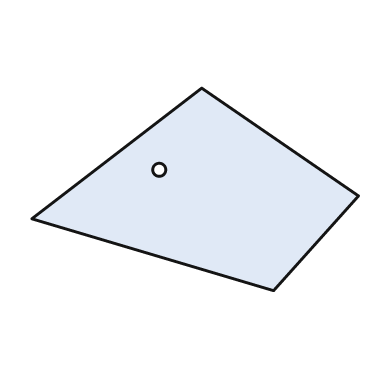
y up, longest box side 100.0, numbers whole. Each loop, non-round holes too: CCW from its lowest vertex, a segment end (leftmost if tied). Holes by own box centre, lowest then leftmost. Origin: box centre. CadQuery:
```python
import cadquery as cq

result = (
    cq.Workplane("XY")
    .moveTo(24.0, -31.0)
    .lineTo(50.0, -2.0)
    .lineTo(2.0, 31.0)
    .lineTo(-50.0, -9.0)
    .close()
    .moveTo(-11.0, 6.0)
    .circle(2.0)
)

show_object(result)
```